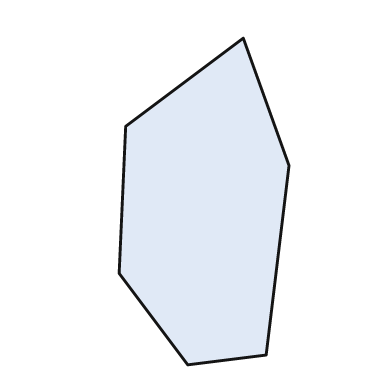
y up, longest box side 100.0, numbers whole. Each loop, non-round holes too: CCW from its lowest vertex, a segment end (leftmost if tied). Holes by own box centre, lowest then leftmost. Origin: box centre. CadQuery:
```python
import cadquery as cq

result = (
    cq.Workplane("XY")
    .moveTo(-5.0, -50.0)
    .lineTo(19.0, -47.0)
    .lineTo(26.0, 11.0)
    .lineTo(12.0, 50.0)
    .lineTo(-24.0, 23.0)
    .lineTo(-26.0, -22.0)
    .close()
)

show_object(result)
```